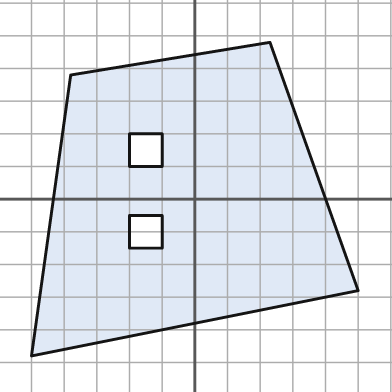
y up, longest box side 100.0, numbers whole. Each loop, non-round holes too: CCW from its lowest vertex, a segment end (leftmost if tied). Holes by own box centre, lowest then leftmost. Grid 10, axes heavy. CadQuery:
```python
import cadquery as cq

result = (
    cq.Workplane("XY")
    .moveTo(-50.0, -48.0)
    .lineTo(50.0, -28.0)
    .lineTo(23.0, 48.0)
    .lineTo(-38.0, 38.0)
    .close()
    .moveTo(-20.0, -15.0)
    .lineTo(-10.0, -15.0)
    .lineTo(-10.0, -5.0)
    .lineTo(-20.0, -5.0)
    .close()
    .moveTo(-20.0, 10.0)
    .lineTo(-10.0, 10.0)
    .lineTo(-10.0, 20.0)
    .lineTo(-20.0, 20.0)
    .close()
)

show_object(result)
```